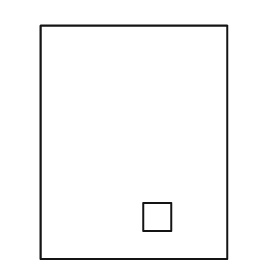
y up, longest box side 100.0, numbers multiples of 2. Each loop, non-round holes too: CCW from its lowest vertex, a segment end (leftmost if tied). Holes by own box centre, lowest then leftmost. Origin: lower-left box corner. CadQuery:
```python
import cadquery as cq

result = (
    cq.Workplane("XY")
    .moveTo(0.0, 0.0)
    .lineTo(80.0, 0.0)
    .lineTo(80.0, 100.0)
    .lineTo(0.0, 100.0)
    .close()
    .moveTo(44.0, 12.0)
    .lineTo(56.0, 12.0)
    .lineTo(56.0, 24.0)
    .lineTo(44.0, 24.0)
    .close()
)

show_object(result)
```